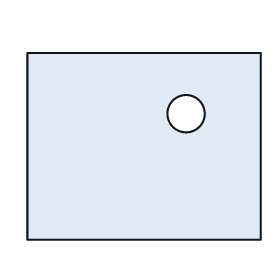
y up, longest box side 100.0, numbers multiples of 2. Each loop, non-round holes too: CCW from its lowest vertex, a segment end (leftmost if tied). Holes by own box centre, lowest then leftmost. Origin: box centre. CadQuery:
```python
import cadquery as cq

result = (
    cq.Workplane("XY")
    .moveTo(-50.0, -40.0)
    .lineTo(50.0, -40.0)
    .lineTo(50.0, 40.0)
    .lineTo(-50.0, 40.0)
    .close()
    .moveTo(18.0, 14.0)
    .circle(8.0)
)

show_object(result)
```